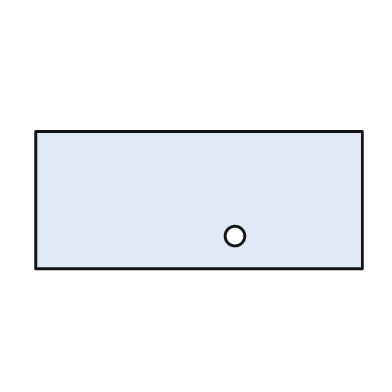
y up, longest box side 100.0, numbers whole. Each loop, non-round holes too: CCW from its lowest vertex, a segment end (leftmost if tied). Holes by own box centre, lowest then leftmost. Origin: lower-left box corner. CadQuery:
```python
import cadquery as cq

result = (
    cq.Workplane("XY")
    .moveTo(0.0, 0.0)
    .lineTo(100.0, 0.0)
    .lineTo(100.0, 42.0)
    .lineTo(0.0, 42.0)
    .close()
    .moveTo(61.0, 10.0)
    .circle(3.0)
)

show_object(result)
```